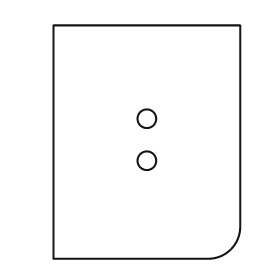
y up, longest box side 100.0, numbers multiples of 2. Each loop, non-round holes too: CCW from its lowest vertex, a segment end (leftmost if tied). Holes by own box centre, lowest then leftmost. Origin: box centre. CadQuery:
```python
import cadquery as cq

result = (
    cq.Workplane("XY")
    .moveTo(-40.0, -50.0)
    .lineTo(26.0, -50.0)
    .threePointArc((36.0, -46.0), (40.0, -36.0))
    .lineTo(40.0, 50.0)
    .lineTo(-40.0, 50.0)
    .close()
    .moveTo(0.0, -8.0)
    .circle(4.0)
    .moveTo(0.0, 10.0)
    .circle(4.0)
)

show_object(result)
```